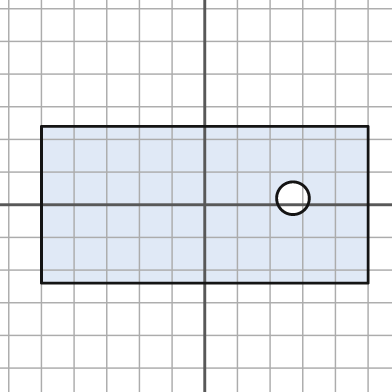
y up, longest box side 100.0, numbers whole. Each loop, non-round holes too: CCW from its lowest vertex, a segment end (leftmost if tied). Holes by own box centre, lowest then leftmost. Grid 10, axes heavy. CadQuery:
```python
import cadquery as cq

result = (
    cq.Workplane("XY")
    .moveTo(-50.0, -24.0)
    .lineTo(50.0, -24.0)
    .lineTo(50.0, 24.0)
    .lineTo(-50.0, 24.0)
    .close()
    .moveTo(27.0, 2.0)
    .circle(5.0)
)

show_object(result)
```